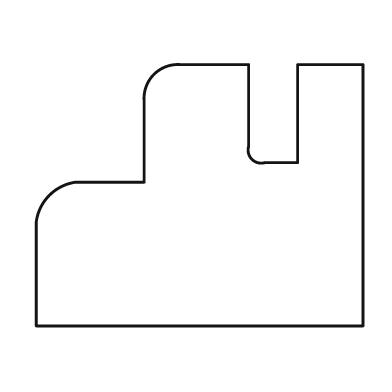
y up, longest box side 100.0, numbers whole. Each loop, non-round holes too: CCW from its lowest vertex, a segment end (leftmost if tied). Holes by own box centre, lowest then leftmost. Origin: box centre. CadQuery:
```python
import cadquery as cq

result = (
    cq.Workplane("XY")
    .moveTo(-50.0, -40.0)
    .lineTo(50.0, -40.0)
    .lineTo(50.0, 40.0)
    .lineTo(30.0, 40.0)
    .lineTo(30.0, 10.0)
    .lineTo(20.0, 10.0)
    .threePointArc((16.0, 11.0), (15.0, 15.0))
    .lineTo(15.0, 40.0)
    .lineTo(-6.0, 40.0)
    .threePointArc((-14.0, 37.0), (-17.0, 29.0))
    .lineTo(-17.0, 4.0)
    .lineTo(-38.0, 4.0)
    .threePointArc((-46.0, 0.0), (-50.0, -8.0))
    .close()
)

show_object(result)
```